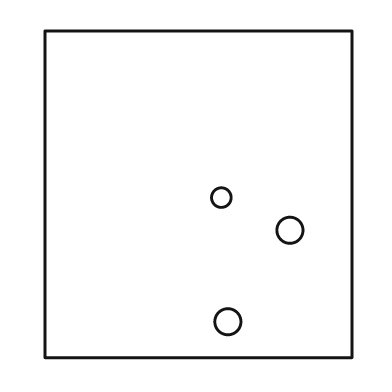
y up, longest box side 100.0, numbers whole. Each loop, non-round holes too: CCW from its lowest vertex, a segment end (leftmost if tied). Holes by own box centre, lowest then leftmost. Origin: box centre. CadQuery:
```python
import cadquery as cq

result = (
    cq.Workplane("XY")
    .moveTo(-47.0, -50.0)
    .lineTo(47.0, -50.0)
    .lineTo(47.0, 50.0)
    .lineTo(-47.0, 50.0)
    .close()
    .moveTo(9.0, -39.0)
    .circle(4.0)
    .moveTo(28.0, -11.0)
    .circle(4.0)
    .moveTo(7.0, -1.0)
    .circle(3.0)
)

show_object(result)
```